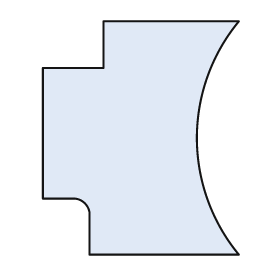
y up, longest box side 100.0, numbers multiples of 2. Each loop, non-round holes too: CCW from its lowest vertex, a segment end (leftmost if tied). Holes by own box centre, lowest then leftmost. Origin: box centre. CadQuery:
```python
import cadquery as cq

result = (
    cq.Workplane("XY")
    .moveTo(-22.0, -50.0)
    .lineTo(42.0, -50.0)
    .threePointArc((24.0, 0.0), (42.0, 50.0))
    .lineTo(-16.0, 50.0)
    .lineTo(-16.0, 30.0)
    .lineTo(-42.0, 30.0)
    .lineTo(-42.0, -26.0)
    .lineTo(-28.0, -26.0)
    .threePointArc((-24.0, -28.0), (-22.0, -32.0))
    .close()
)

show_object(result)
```